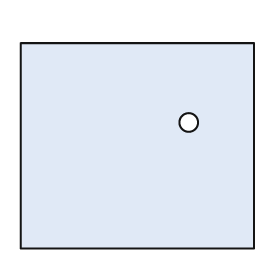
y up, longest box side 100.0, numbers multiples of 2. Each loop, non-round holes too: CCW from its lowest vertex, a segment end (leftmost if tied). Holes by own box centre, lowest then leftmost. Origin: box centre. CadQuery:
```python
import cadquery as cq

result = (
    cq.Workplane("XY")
    .moveTo(-50.0, -44.0)
    .lineTo(50.0, -44.0)
    .lineTo(50.0, 44.0)
    .lineTo(-50.0, 44.0)
    .close()
    .moveTo(22.0, 10.0)
    .circle(4.0)
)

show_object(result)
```